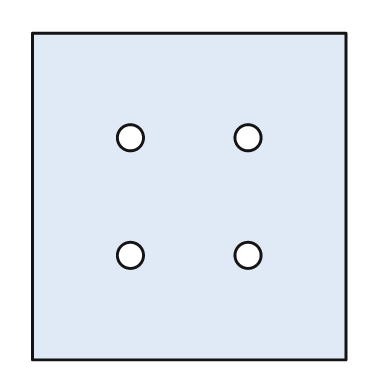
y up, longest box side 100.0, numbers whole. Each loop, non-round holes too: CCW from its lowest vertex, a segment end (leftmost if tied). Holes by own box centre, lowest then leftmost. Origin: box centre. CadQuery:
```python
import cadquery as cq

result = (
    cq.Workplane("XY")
    .moveTo(-48.0, -50.0)
    .lineTo(48.0, -50.0)
    .lineTo(48.0, 50.0)
    .lineTo(-48.0, 50.0)
    .close()
    .moveTo(-18.0, -18.0)
    .circle(4.0)
    .moveTo(18.0, -18.0)
    .circle(4.0)
    .moveTo(-18.0, 18.0)
    .circle(4.0)
    .moveTo(18.0, 18.0)
    .circle(4.0)
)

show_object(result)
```